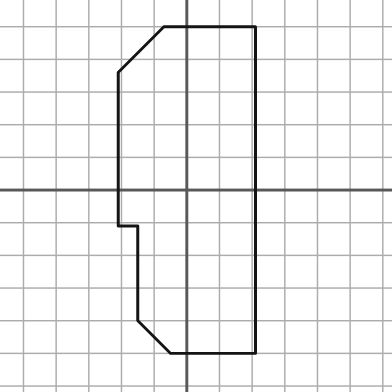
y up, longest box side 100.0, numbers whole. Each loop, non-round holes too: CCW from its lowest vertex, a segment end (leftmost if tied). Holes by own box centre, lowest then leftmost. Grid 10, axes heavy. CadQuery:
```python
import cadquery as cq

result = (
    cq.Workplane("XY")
    .moveTo(-5.0, -50.0)
    .lineTo(21.0, -50.0)
    .lineTo(21.0, 50.0)
    .lineTo(-7.0, 50.0)
    .lineTo(-21.0, 36.0)
    .lineTo(-21.0, -11.0)
    .lineTo(-15.0, -11.0)
    .lineTo(-15.0, -40.0)
    .close()
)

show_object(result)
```